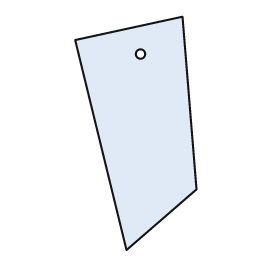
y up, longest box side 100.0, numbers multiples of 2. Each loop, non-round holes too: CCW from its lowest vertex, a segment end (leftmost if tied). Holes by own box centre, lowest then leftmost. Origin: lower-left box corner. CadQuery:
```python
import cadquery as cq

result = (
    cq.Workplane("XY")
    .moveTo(22.0, 0.0)
    .lineTo(52.0, 26.0)
    .lineTo(46.0, 100.0)
    .lineTo(0.0, 90.0)
    .close()
    .moveTo(28.0, 84.0)
    .circle(2.0)
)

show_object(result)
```